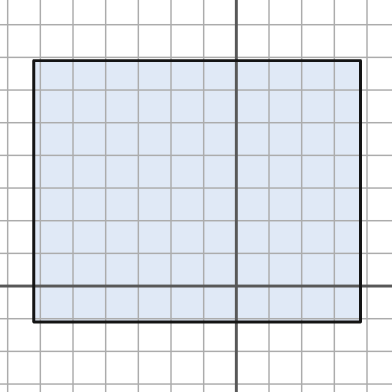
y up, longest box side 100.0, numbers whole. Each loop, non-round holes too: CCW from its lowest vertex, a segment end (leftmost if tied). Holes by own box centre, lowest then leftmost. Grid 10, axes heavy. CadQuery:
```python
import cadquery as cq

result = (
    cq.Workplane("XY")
    .moveTo(-62.0, -11.0)
    .lineTo(38.0, -11.0)
    .lineTo(38.0, 69.0)
    .lineTo(-62.0, 69.0)
    .close()
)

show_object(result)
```